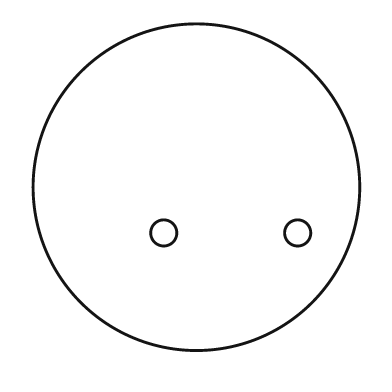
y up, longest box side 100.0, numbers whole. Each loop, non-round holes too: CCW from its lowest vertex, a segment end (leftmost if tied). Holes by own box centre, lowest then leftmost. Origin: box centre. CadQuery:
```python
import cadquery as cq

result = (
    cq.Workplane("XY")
    .moveTo(0.0, 0.0)
    .circle(50.0)
    .moveTo(-10.0, -14.0)
    .circle(4.0)
    .moveTo(31.0, -14.0)
    .circle(4.0)
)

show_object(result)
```